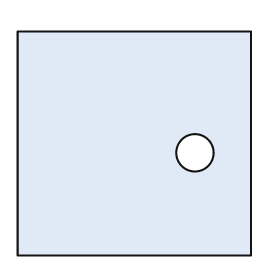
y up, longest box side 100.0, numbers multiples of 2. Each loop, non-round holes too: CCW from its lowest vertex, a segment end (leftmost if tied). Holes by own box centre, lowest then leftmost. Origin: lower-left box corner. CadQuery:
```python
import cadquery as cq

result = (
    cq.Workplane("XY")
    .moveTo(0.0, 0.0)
    .lineTo(100.0, 0.0)
    .lineTo(100.0, 96.0)
    .lineTo(0.0, 96.0)
    .close()
    .moveTo(76.0, 44.0)
    .circle(8.0)
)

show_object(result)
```